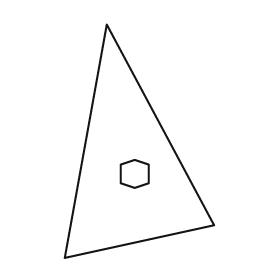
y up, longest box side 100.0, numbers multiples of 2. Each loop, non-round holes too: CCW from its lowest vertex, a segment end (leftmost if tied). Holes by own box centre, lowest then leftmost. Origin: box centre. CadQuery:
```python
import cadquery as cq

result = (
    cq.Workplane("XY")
    .moveTo(-32.0, -50.0)
    .lineTo(32.0, -36.0)
    .lineTo(-14.0, 50.0)
    .close()
    .moveTo(-2.0, -20.0)
    .lineTo(4.0, -18.0)
    .lineTo(4.0, -10.0)
    .lineTo(-2.0, -8.0)
    .lineTo(-8.0, -10.0)
    .lineTo(-8.0, -18.0)
    .close()
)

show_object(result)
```